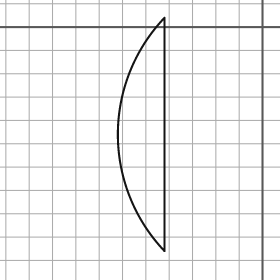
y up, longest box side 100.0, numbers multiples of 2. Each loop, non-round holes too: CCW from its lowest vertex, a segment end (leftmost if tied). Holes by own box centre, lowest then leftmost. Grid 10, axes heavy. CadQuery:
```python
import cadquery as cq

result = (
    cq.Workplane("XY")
    .moveTo(-42.0, -96.0)
    .lineTo(-42.0, 4.0)
    .threePointArc((-62.0, -46.0), (-42.0, -96.0))
    .close()
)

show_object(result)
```